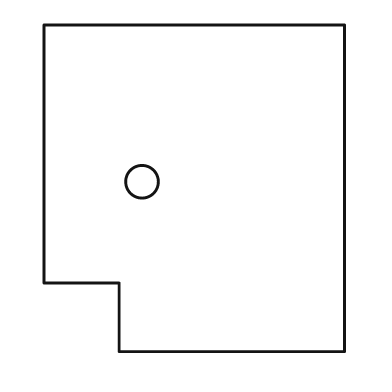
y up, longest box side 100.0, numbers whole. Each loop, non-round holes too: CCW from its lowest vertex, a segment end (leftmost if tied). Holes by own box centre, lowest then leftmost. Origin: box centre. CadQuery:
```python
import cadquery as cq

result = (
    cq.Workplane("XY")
    .moveTo(-23.0, -50.0)
    .lineTo(46.0, -50.0)
    .lineTo(46.0, 50.0)
    .lineTo(-46.0, 50.0)
    .lineTo(-46.0, -29.0)
    .lineTo(-23.0, -29.0)
    .close()
    .moveTo(-16.0, 2.0)
    .circle(5.0)
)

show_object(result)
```